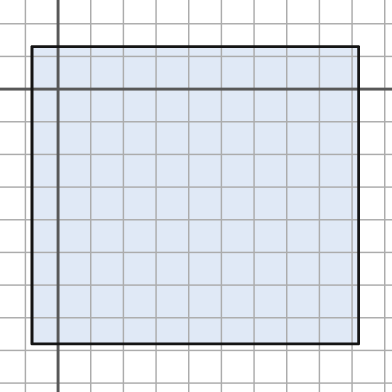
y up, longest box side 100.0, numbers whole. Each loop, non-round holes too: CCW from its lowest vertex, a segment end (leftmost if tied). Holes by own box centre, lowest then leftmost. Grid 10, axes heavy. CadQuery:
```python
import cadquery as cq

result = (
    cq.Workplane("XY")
    .moveTo(-8.0, -78.0)
    .lineTo(92.0, -78.0)
    .lineTo(92.0, 13.0)
    .lineTo(-8.0, 13.0)
    .close()
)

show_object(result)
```